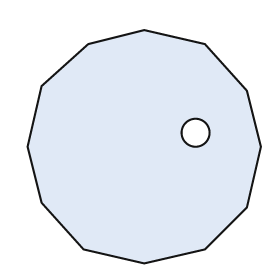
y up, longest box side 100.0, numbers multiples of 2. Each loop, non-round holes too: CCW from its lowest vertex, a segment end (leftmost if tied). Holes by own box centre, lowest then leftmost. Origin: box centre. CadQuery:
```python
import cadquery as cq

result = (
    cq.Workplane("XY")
    .moveTo(0.0, -50.0)
    .lineTo(26.0, -44.0)
    .lineTo(44.0, -26.0)
    .lineTo(50.0, 0.0)
    .lineTo(44.0, 24.0)
    .lineTo(26.0, 44.0)
    .lineTo(0.0, 50.0)
    .lineTo(-24.0, 44.0)
    .lineTo(-44.0, 26.0)
    .lineTo(-50.0, 0.0)
    .lineTo(-44.0, -24.0)
    .lineTo(-26.0, -44.0)
    .close()
    .moveTo(22.0, 6.0)
    .circle(6.0)
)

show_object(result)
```